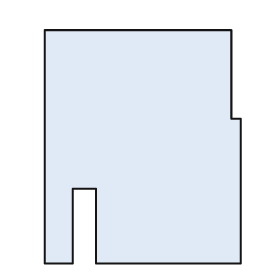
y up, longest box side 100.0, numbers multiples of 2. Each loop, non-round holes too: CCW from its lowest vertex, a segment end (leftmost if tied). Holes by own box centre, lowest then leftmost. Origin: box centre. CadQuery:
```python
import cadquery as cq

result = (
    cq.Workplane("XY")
    .moveTo(-42.0, -50.0)
    .lineTo(-30.0, -50.0)
    .lineTo(-30.0, -18.0)
    .lineTo(-20.0, -18.0)
    .lineTo(-20.0, -50.0)
    .lineTo(42.0, -50.0)
    .lineTo(42.0, 12.0)
    .lineTo(38.0, 12.0)
    .lineTo(38.0, 50.0)
    .lineTo(-42.0, 50.0)
    .close()
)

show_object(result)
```